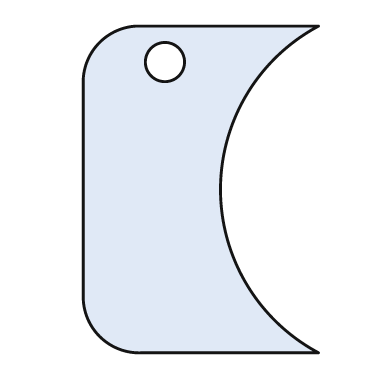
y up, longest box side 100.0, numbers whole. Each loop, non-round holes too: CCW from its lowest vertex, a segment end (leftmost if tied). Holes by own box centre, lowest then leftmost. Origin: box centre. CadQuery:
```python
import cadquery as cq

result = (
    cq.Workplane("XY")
    .moveTo(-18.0, -50.0)
    .lineTo(36.0, -50.0)
    .threePointArc((6.0, 0.0), (36.0, 50.0))
    .lineTo(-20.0, 50.0)
    .threePointArc((-31.0, 45.0), (-36.0, 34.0))
    .lineTo(-36.0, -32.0)
    .threePointArc((-31.0, -45.0), (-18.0, -50.0))
    .close()
    .moveTo(-11.0, 39.0)
    .circle(6.0)
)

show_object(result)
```